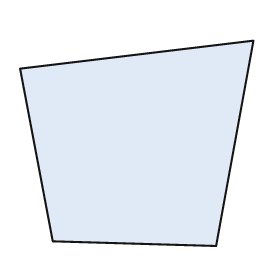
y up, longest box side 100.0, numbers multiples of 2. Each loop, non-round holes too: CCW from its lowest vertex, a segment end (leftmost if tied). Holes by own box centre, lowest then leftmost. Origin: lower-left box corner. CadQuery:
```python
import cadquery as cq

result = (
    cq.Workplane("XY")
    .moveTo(84.0, 0.0)
    .lineTo(100.0, 88.0)
    .lineTo(0.0, 76.0)
    .lineTo(14.0, 2.0)
    .close()
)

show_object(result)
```